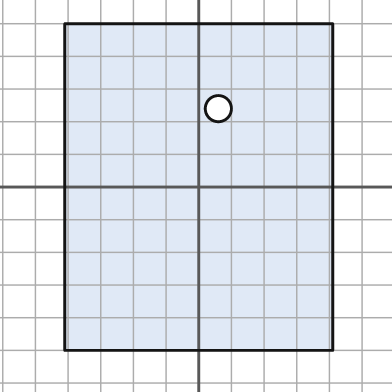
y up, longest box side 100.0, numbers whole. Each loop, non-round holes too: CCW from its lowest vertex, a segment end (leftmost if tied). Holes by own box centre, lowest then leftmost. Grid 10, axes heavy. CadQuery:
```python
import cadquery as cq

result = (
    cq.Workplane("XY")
    .moveTo(-41.0, -50.0)
    .lineTo(41.0, -50.0)
    .lineTo(41.0, 50.0)
    .lineTo(-41.0, 50.0)
    .close()
    .moveTo(6.0, 24.0)
    .circle(4.0)
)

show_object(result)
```